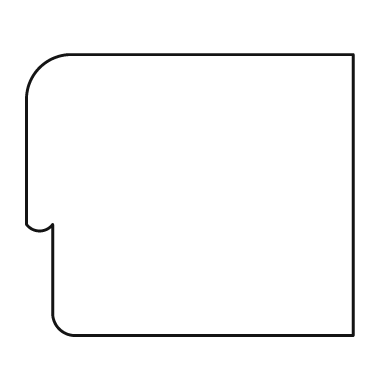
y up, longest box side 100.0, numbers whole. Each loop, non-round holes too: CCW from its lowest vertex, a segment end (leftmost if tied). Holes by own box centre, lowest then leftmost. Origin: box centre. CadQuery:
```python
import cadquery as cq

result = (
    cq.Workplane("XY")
    .moveTo(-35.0, -43.0)
    .lineTo(50.0, -43.0)
    .lineTo(50.0, 43.0)
    .lineTo(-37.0, 43.0)
    .threePointArc((-46.0, 39.0), (-50.0, 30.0))
    .lineTo(-50.0, -9.0)
    .threePointArc((-46.0, -11.0), (-42.0, -9.0))
    .lineTo(-42.0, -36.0)
    .threePointArc((-40.0, -41.0), (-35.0, -43.0))
    .close()
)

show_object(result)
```